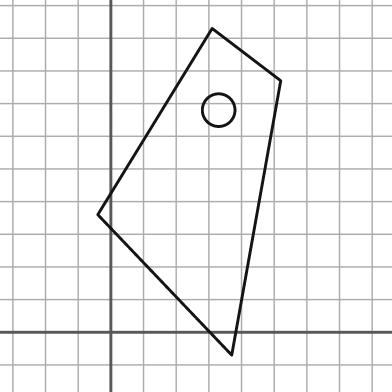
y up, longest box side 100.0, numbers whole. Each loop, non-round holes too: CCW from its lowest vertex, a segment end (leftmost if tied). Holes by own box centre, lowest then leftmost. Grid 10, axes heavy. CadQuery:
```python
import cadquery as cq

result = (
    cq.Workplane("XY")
    .moveTo(37.0, -7.0)
    .lineTo(52.0, 77.0)
    .lineTo(31.0, 93.0)
    .lineTo(-4.0, 36.0)
    .close()
    .moveTo(33.0, 68.0)
    .circle(5.0)
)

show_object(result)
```